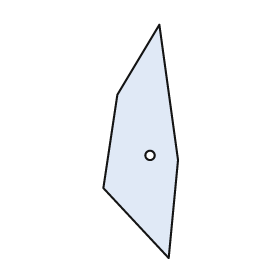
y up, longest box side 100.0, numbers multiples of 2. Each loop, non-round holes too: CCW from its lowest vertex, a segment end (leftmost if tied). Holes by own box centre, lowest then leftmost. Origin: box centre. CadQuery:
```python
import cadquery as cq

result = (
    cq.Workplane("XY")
    .moveTo(12.0, -50.0)
    .lineTo(16.0, -8.0)
    .lineTo(8.0, 50.0)
    .lineTo(-10.0, 20.0)
    .lineTo(-16.0, -20.0)
    .close()
    .moveTo(4.0, -6.0)
    .circle(2.0)
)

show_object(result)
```